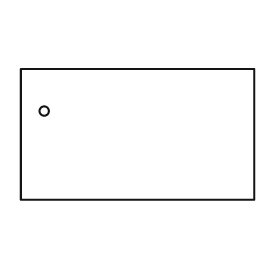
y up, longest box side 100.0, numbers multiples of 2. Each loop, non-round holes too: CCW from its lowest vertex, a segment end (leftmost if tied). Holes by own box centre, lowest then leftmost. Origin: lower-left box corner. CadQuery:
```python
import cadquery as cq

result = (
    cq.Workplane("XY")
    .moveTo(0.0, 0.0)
    .lineTo(100.0, 0.0)
    .lineTo(100.0, 56.0)
    .lineTo(0.0, 56.0)
    .close()
    .moveTo(10.0, 38.0)
    .circle(2.0)
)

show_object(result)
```